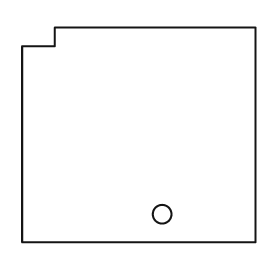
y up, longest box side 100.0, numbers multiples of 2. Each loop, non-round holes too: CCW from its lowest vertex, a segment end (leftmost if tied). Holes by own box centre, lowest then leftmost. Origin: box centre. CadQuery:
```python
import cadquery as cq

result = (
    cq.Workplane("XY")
    .moveTo(-50.0, -46.0)
    .lineTo(50.0, -46.0)
    .lineTo(50.0, 46.0)
    .lineTo(-36.0, 46.0)
    .lineTo(-36.0, 38.0)
    .lineTo(-50.0, 38.0)
    .close()
    .moveTo(10.0, -34.0)
    .circle(4.0)
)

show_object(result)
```